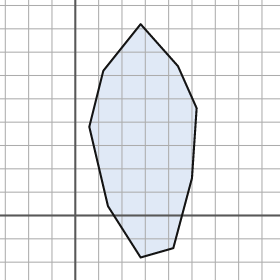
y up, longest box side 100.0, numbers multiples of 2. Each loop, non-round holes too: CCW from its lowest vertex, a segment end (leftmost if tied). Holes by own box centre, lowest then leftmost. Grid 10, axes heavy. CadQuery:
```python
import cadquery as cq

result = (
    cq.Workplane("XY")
    .moveTo(28.0, -18.0)
    .lineTo(42.0, -14.0)
    .lineTo(50.0, 16.0)
    .lineTo(52.0, 46.0)
    .lineTo(44.0, 64.0)
    .lineTo(28.0, 82.0)
    .lineTo(12.0, 62.0)
    .lineTo(6.0, 38.0)
    .lineTo(14.0, 4.0)
    .close()
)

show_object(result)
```